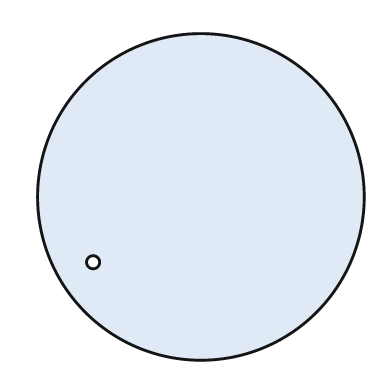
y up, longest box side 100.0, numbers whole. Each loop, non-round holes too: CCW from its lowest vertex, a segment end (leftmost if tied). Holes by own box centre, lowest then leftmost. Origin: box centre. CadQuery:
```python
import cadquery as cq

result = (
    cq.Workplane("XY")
    .moveTo(0.0, 0.0)
    .circle(50.0)
    .moveTo(-33.0, -20.0)
    .circle(2.0)
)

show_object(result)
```